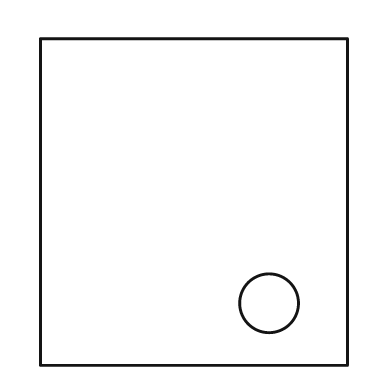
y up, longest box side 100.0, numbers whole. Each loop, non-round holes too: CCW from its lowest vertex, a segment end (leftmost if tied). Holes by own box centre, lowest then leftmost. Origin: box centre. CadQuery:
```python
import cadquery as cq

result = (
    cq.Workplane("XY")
    .moveTo(-47.0, -50.0)
    .lineTo(47.0, -50.0)
    .lineTo(47.0, 50.0)
    .lineTo(-47.0, 50.0)
    .close()
    .moveTo(23.0, -31.0)
    .circle(9.0)
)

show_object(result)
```